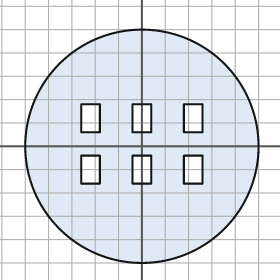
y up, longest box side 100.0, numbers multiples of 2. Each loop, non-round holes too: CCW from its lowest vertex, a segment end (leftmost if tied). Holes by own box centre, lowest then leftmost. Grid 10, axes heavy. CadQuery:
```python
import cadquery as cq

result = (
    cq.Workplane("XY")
    .moveTo(0.0, 0.0)
    .circle(50.0)
    .moveTo(-26.0, -16.0)
    .lineTo(-18.0, -16.0)
    .lineTo(-18.0, -4.0)
    .lineTo(-26.0, -4.0)
    .close()
    .moveTo(-4.0, -16.0)
    .lineTo(4.0, -16.0)
    .lineTo(4.0, -4.0)
    .lineTo(-4.0, -4.0)
    .close()
    .moveTo(18.0, -16.0)
    .lineTo(26.0, -16.0)
    .lineTo(26.0, -4.0)
    .lineTo(18.0, -4.0)
    .close()
    .moveTo(-26.0, 6.0)
    .lineTo(-18.0, 6.0)
    .lineTo(-18.0, 18.0)
    .lineTo(-26.0, 18.0)
    .close()
    .moveTo(-4.0, 6.0)
    .lineTo(4.0, 6.0)
    .lineTo(4.0, 18.0)
    .lineTo(-4.0, 18.0)
    .close()
    .moveTo(18.0, 6.0)
    .lineTo(26.0, 6.0)
    .lineTo(26.0, 18.0)
    .lineTo(18.0, 18.0)
    .close()
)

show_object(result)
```